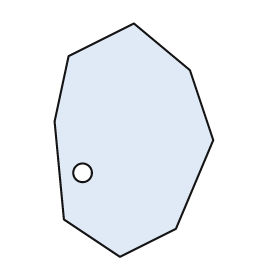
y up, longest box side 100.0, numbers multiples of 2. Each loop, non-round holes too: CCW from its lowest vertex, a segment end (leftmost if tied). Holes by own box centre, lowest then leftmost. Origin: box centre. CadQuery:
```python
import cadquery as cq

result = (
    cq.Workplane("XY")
    .moveTo(-6.0, -50.0)
    .lineTo(18.0, -38.0)
    .lineTo(34.0, 0.0)
    .lineTo(24.0, 30.0)
    .lineTo(0.0, 50.0)
    .lineTo(-28.0, 36.0)
    .lineTo(-34.0, 8.0)
    .lineTo(-30.0, -34.0)
    .close()
    .moveTo(-22.0, -14.0)
    .circle(4.0)
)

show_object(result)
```